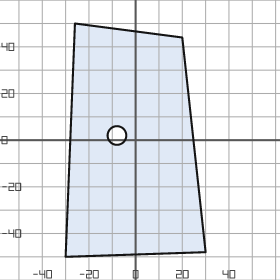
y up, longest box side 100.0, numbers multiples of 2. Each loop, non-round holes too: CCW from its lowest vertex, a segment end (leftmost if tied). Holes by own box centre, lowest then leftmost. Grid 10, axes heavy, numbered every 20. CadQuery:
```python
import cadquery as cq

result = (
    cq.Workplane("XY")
    .moveTo(-30.0, -50.0)
    .lineTo(30.0, -48.0)
    .lineTo(20.0, 44.0)
    .lineTo(-26.0, 50.0)
    .close()
    .moveTo(-8.0, 2.0)
    .circle(4.0)
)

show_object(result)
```